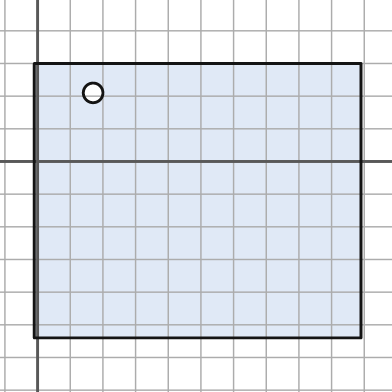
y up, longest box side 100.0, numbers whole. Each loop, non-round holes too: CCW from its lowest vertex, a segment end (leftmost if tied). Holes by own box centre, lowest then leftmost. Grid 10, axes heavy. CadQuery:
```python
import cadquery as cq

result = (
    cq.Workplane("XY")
    .moveTo(-1.0, -54.0)
    .lineTo(99.0, -54.0)
    .lineTo(99.0, 30.0)
    .lineTo(-1.0, 30.0)
    .close()
    .moveTo(17.0, 21.0)
    .circle(3.0)
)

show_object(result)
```